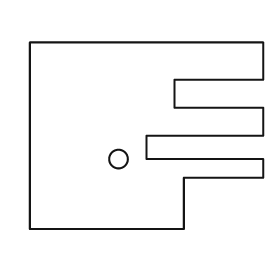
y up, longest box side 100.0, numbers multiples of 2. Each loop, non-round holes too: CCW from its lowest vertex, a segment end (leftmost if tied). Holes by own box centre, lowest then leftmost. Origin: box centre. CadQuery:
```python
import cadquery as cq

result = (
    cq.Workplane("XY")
    .moveTo(-50.0, -40.0)
    .lineTo(16.0, -40.0)
    .lineTo(16.0, -18.0)
    .lineTo(50.0, -18.0)
    .lineTo(50.0, -10.0)
    .lineTo(0.0, -10.0)
    .lineTo(0.0, 0.0)
    .lineTo(50.0, 0.0)
    .lineTo(50.0, 12.0)
    .lineTo(12.0, 12.0)
    .lineTo(12.0, 24.0)
    .lineTo(50.0, 24.0)
    .lineTo(50.0, 40.0)
    .lineTo(-50.0, 40.0)
    .close()
    .moveTo(-12.0, -10.0)
    .circle(4.0)
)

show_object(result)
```